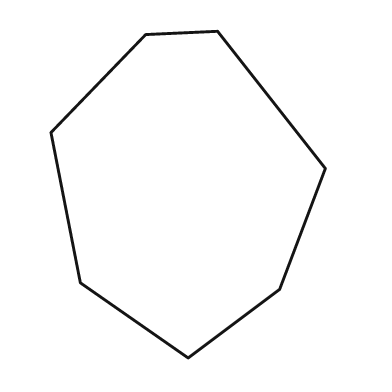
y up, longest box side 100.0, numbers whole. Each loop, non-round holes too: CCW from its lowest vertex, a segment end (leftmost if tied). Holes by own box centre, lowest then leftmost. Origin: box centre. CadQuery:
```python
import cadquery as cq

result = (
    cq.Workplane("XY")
    .moveTo(0.0, -50.0)
    .lineTo(28.0, -29.0)
    .lineTo(42.0, 8.0)
    .lineTo(9.0, 50.0)
    .lineTo(-13.0, 49.0)
    .lineTo(-42.0, 19.0)
    .lineTo(-33.0, -27.0)
    .close()
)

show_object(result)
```